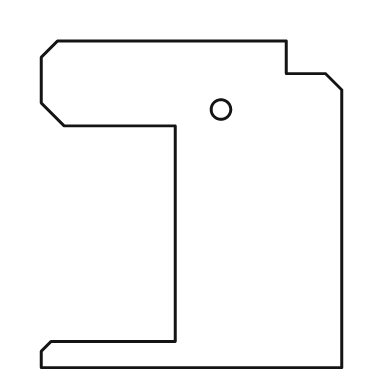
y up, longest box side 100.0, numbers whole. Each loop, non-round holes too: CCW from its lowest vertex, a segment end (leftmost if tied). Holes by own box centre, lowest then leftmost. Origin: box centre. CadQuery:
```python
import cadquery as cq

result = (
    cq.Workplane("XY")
    .moveTo(-46.0, -50.0)
    .lineTo(46.0, -50.0)
    .lineTo(46.0, 35.0)
    .lineTo(41.0, 40.0)
    .lineTo(29.0, 40.0)
    .lineTo(29.0, 50.0)
    .lineTo(-41.0, 50.0)
    .lineTo(-46.0, 45.0)
    .lineTo(-46.0, 31.0)
    .lineTo(-39.0, 24.0)
    .lineTo(-5.0, 24.0)
    .lineTo(-5.0, -42.0)
    .lineTo(-43.0, -42.0)
    .lineTo(-46.0, -45.0)
    .close()
    .moveTo(9.0, 29.0)
    .circle(3.0)
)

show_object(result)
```